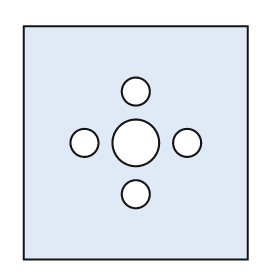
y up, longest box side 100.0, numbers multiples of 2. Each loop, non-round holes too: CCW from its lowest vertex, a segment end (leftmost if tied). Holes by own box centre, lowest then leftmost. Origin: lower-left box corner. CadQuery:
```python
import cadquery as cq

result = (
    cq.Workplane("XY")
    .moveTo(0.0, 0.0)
    .lineTo(96.0, 0.0)
    .lineTo(96.0, 100.0)
    .lineTo(0.0, 100.0)
    .close()
    .moveTo(48.0, 28.0)
    .circle(6.0)
    .moveTo(26.0, 50.0)
    .circle(6.0)
    .moveTo(48.0, 50.0)
    .circle(10.0)
    .moveTo(70.0, 50.0)
    .circle(6.0)
    .moveTo(48.0, 72.0)
    .circle(6.0)
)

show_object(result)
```